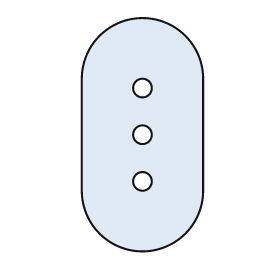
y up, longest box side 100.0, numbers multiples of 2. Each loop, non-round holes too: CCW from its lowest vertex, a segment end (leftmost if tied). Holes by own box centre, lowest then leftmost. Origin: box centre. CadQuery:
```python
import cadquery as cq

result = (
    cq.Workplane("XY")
    .moveTo(-26.0, -24.0)
    .threePointArc((0.0, -50.0), (26.0, -24.0))
    .lineTo(26.0, 24.0)
    .threePointArc((0.0, 50.0), (-26.0, 24.0))
    .close()
    .moveTo(0.0, -20.0)
    .circle(4.0)
    .moveTo(0.0, 0.0)
    .circle(4.0)
    .moveTo(0.0, 20.0)
    .circle(4.0)
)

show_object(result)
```